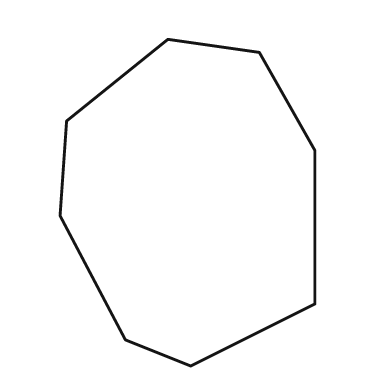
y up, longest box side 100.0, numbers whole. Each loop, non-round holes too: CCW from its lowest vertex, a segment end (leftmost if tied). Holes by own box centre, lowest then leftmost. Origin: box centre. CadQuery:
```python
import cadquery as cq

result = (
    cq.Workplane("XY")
    .moveTo(1.0, -50.0)
    .lineTo(39.0, -31.0)
    .lineTo(39.0, 16.0)
    .lineTo(22.0, 46.0)
    .lineTo(-6.0, 50.0)
    .lineTo(-37.0, 25.0)
    .lineTo(-39.0, -4.0)
    .lineTo(-19.0, -42.0)
    .close()
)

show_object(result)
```